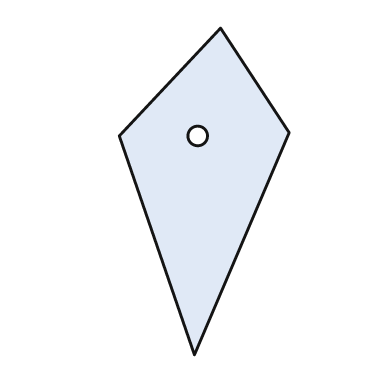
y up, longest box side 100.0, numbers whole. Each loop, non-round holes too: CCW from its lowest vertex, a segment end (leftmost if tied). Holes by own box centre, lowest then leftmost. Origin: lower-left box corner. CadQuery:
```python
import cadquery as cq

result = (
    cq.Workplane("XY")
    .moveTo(23.0, 0.0)
    .lineTo(52.0, 68.0)
    .lineTo(31.0, 100.0)
    .lineTo(0.0, 67.0)
    .close()
    .moveTo(24.0, 67.0)
    .circle(3.0)
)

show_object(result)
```